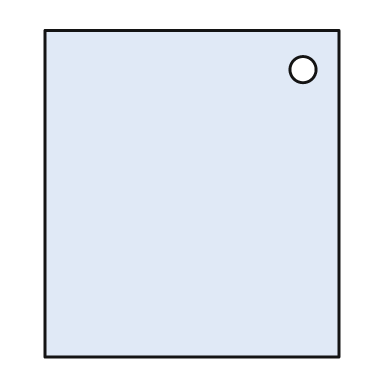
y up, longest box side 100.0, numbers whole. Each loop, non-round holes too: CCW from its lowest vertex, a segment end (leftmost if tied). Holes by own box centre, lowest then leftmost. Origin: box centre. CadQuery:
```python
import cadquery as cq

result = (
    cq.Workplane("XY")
    .moveTo(-45.0, -50.0)
    .lineTo(45.0, -50.0)
    .lineTo(45.0, 50.0)
    .lineTo(-45.0, 50.0)
    .close()
    .moveTo(34.0, 38.0)
    .circle(4.0)
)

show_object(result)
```